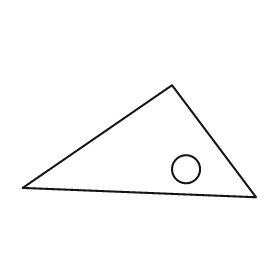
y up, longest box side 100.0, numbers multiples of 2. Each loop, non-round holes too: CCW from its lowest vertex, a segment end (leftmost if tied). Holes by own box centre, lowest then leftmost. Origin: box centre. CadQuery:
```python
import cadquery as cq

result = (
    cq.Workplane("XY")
    .moveTo(50.0, -24.0)
    .lineTo(14.0, 24.0)
    .lineTo(-50.0, -20.0)
    .close()
    .moveTo(20.0, -12.0)
    .circle(6.0)
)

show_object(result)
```